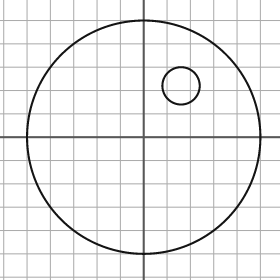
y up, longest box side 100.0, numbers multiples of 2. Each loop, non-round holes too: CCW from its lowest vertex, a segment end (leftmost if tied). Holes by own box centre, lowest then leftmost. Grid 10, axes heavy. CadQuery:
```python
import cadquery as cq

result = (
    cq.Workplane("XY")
    .moveTo(0.0, 0.0)
    .circle(50.0)
    .moveTo(16.0, 22.0)
    .circle(8.0)
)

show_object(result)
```